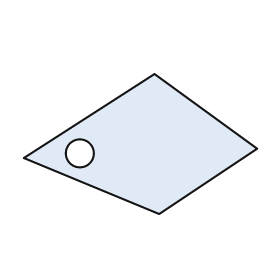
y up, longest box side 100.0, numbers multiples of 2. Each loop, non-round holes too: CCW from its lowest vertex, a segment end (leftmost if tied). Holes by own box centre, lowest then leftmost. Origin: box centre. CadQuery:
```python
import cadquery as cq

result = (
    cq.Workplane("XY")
    .moveTo(8.0, -30.0)
    .lineTo(50.0, -2.0)
    .lineTo(6.0, 30.0)
    .lineTo(-50.0, -6.0)
    .close()
    .moveTo(-26.0, -4.0)
    .circle(6.0)
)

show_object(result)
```